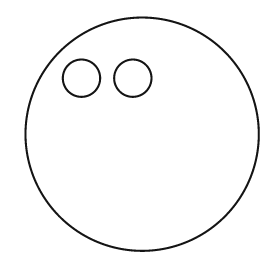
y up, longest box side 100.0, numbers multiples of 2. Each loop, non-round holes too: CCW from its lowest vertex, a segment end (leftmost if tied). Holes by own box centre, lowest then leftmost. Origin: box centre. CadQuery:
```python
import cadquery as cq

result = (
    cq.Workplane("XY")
    .moveTo(0.0, 0.0)
    .circle(50.0)
    .moveTo(-26.0, 24.0)
    .circle(8.0)
    .moveTo(-4.0, 24.0)
    .circle(8.0)
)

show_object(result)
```